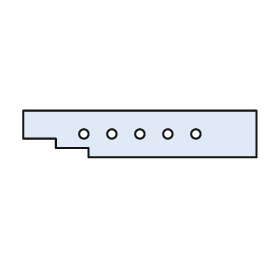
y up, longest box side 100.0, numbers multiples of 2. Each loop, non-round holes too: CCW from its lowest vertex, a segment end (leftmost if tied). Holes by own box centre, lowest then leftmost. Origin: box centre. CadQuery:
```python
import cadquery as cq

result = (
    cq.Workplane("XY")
    .moveTo(-22.0, -10.0)
    .lineTo(50.0, -10.0)
    .lineTo(50.0, 10.0)
    .lineTo(-50.0, 10.0)
    .lineTo(-50.0, -2.0)
    .lineTo(-36.0, -2.0)
    .lineTo(-36.0, -6.0)
    .lineTo(-22.0, -6.0)
    .close()
    .moveTo(-24.0, 0.0)
    .circle(2.0)
    .moveTo(-12.0, 0.0)
    .circle(2.0)
    .moveTo(0.0, 0.0)
    .circle(2.0)
    .moveTo(12.0, 0.0)
    .circle(2.0)
    .moveTo(24.0, 0.0)
    .circle(2.0)
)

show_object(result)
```